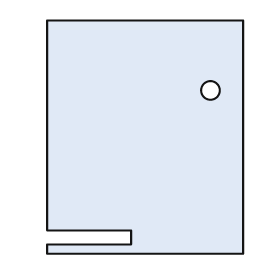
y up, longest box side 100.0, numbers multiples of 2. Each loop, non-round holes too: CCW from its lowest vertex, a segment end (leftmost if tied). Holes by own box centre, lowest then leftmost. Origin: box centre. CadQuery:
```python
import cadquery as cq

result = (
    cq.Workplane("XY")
    .moveTo(-42.0, -50.0)
    .lineTo(42.0, -50.0)
    .lineTo(42.0, 50.0)
    .lineTo(-42.0, 50.0)
    .lineTo(-42.0, -40.0)
    .lineTo(-6.0, -40.0)
    .lineTo(-6.0, -46.0)
    .lineTo(-42.0, -46.0)
    .close()
    .moveTo(28.0, 20.0)
    .circle(4.0)
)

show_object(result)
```